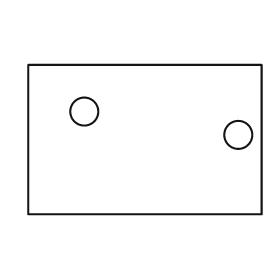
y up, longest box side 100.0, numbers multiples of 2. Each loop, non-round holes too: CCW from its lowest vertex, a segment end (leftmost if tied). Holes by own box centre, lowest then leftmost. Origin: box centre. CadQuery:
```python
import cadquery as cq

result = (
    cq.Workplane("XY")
    .moveTo(-50.0, -32.0)
    .lineTo(50.0, -32.0)
    .lineTo(50.0, 32.0)
    .lineTo(-50.0, 32.0)
    .close()
    .moveTo(40.0, 2.0)
    .circle(6.0)
    .moveTo(-26.0, 12.0)
    .circle(6.0)
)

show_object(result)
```